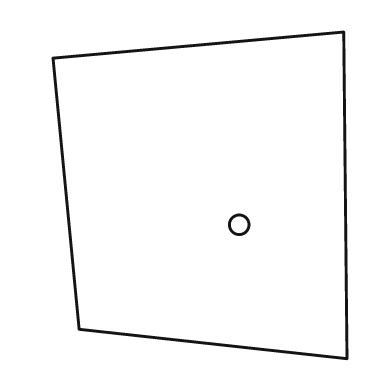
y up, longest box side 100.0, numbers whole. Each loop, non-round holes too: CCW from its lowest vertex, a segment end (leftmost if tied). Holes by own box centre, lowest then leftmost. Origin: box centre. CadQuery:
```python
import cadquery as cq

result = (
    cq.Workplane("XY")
    .moveTo(45.0, -50.0)
    .lineTo(44.0, 50.0)
    .lineTo(-45.0, 42.0)
    .lineTo(-37.0, -41.0)
    .close()
    .moveTo(12.0, -9.0)
    .circle(3.0)
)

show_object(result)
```